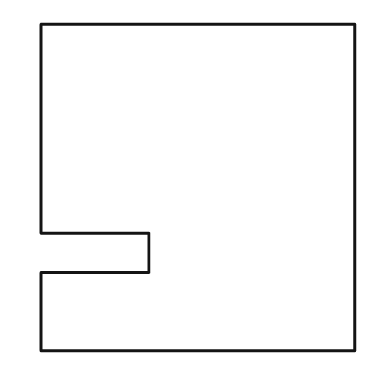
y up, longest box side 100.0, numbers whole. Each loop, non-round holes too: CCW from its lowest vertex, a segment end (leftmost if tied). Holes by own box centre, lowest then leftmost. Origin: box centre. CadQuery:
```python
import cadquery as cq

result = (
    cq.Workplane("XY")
    .moveTo(-48.0, -50.0)
    .lineTo(48.0, -50.0)
    .lineTo(48.0, 50.0)
    .lineTo(-48.0, 50.0)
    .lineTo(-48.0, -14.0)
    .lineTo(-15.0, -14.0)
    .lineTo(-15.0, -26.0)
    .lineTo(-48.0, -26.0)
    .close()
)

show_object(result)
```